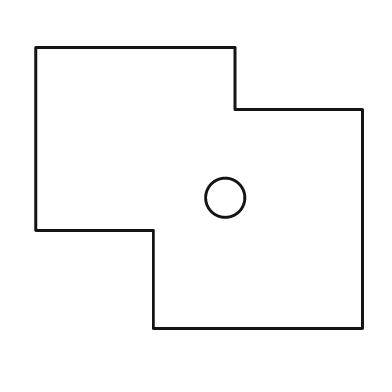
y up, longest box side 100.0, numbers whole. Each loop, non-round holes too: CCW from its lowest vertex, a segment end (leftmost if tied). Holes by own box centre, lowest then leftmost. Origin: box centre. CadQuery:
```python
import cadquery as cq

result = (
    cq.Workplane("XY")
    .moveTo(-14.0, -43.0)
    .lineTo(50.0, -43.0)
    .lineTo(50.0, 24.0)
    .lineTo(11.0, 24.0)
    .lineTo(11.0, 43.0)
    .lineTo(-50.0, 43.0)
    .lineTo(-50.0, -13.0)
    .lineTo(-14.0, -13.0)
    .close()
    .moveTo(8.0, -3.0)
    .circle(6.0)
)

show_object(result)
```